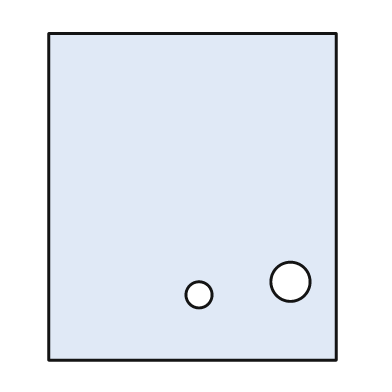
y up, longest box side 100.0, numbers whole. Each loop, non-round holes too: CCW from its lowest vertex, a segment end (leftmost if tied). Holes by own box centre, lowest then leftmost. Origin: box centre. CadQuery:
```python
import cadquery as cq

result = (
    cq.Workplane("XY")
    .moveTo(-44.0, -50.0)
    .lineTo(44.0, -50.0)
    .lineTo(44.0, 50.0)
    .lineTo(-44.0, 50.0)
    .close()
    .moveTo(2.0, -30.0)
    .circle(4.0)
    .moveTo(30.0, -26.0)
    .circle(6.0)
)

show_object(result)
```